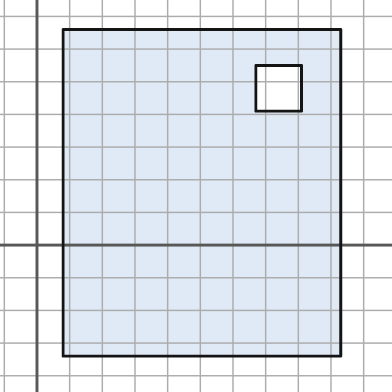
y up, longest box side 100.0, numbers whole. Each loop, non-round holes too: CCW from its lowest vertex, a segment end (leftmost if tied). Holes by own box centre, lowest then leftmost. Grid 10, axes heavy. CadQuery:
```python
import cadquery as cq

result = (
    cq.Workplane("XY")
    .moveTo(8.0, -34.0)
    .lineTo(93.0, -34.0)
    .lineTo(93.0, 66.0)
    .lineTo(8.0, 66.0)
    .close()
    .moveTo(67.0, 41.0)
    .lineTo(81.0, 41.0)
    .lineTo(81.0, 55.0)
    .lineTo(67.0, 55.0)
    .close()
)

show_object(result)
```